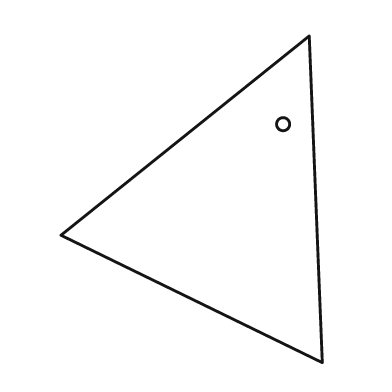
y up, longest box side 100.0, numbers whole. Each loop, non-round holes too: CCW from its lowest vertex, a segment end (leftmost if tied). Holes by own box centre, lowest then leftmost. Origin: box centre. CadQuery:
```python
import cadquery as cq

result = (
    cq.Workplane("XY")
    .moveTo(40.0, -50.0)
    .lineTo(36.0, 50.0)
    .lineTo(-40.0, -11.0)
    .close()
    .moveTo(28.0, 23.0)
    .circle(2.0)
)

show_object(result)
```